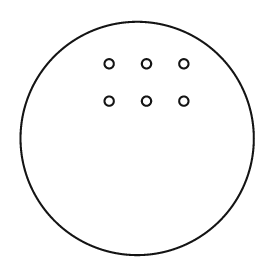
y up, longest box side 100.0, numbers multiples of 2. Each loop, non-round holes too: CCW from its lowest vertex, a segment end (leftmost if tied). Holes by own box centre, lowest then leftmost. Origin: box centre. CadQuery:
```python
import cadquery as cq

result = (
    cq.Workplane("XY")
    .moveTo(0.0, 0.0)
    .circle(50.0)
    .moveTo(-12.0, 16.0)
    .circle(2.0)
    .moveTo(4.0, 16.0)
    .circle(2.0)
    .moveTo(20.0, 16.0)
    .circle(2.0)
    .moveTo(-12.0, 32.0)
    .circle(2.0)
    .moveTo(4.0, 32.0)
    .circle(2.0)
    .moveTo(20.0, 32.0)
    .circle(2.0)
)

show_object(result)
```